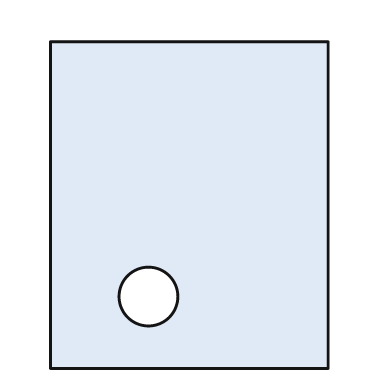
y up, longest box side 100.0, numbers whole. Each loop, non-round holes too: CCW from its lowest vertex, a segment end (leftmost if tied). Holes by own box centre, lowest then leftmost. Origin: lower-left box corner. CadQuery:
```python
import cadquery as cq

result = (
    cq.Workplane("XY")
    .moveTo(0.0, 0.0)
    .lineTo(85.0, 0.0)
    .lineTo(85.0, 100.0)
    .lineTo(0.0, 100.0)
    .close()
    .moveTo(30.0, 22.0)
    .circle(9.0)
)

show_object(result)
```